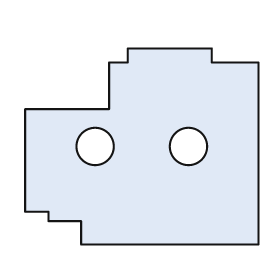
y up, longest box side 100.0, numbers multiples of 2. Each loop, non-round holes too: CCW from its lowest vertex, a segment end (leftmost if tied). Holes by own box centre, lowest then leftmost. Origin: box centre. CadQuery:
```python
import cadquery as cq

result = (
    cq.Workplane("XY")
    .moveTo(-26.0, -42.0)
    .lineTo(50.0, -42.0)
    .lineTo(50.0, 36.0)
    .lineTo(30.0, 36.0)
    .lineTo(30.0, 42.0)
    .lineTo(-6.0, 42.0)
    .lineTo(-6.0, 36.0)
    .lineTo(-14.0, 36.0)
    .lineTo(-14.0, 16.0)
    .lineTo(-50.0, 16.0)
    .lineTo(-50.0, -28.0)
    .lineTo(-40.0, -28.0)
    .lineTo(-40.0, -32.0)
    .lineTo(-26.0, -32.0)
    .close()
    .moveTo(-20.0, 0.0)
    .circle(8.0)
    .moveTo(20.0, 0.0)
    .circle(8.0)
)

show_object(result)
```